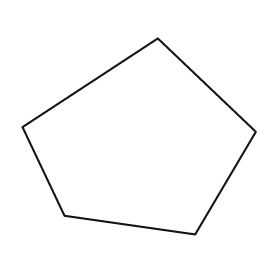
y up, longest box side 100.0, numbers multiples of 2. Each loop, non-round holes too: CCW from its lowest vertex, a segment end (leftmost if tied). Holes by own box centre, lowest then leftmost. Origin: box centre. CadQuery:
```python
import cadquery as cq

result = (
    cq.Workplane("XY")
    .moveTo(24.0, -42.0)
    .lineTo(50.0, 2.0)
    .lineTo(8.0, 42.0)
    .lineTo(-50.0, 4.0)
    .lineTo(-32.0, -34.0)
    .close()
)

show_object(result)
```